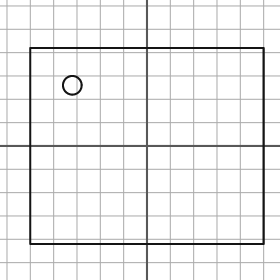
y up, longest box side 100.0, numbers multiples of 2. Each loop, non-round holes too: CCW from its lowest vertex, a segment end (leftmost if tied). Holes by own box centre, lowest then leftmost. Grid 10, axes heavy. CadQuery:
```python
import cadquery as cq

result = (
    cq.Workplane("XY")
    .moveTo(-50.0, -42.0)
    .lineTo(50.0, -42.0)
    .lineTo(50.0, 42.0)
    .lineTo(-50.0, 42.0)
    .close()
    .moveTo(-32.0, 26.0)
    .circle(4.0)
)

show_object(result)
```